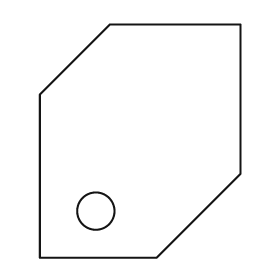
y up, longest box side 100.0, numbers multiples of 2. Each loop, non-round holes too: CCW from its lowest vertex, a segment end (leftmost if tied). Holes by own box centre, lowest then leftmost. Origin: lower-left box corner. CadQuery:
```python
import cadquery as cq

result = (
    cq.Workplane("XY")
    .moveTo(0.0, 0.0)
    .lineTo(50.0, 0.0)
    .lineTo(86.0, 36.0)
    .lineTo(86.0, 100.0)
    .lineTo(30.0, 100.0)
    .lineTo(0.0, 70.0)
    .close()
    .moveTo(24.0, 20.0)
    .circle(8.0)
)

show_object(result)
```